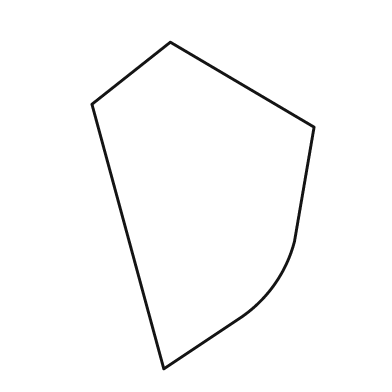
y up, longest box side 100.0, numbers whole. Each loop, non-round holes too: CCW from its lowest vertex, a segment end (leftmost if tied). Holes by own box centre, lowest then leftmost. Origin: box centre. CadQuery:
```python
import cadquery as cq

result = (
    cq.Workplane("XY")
    .moveTo(-12.0, -50.0)
    .lineTo(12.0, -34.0)
    .threePointArc((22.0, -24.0), (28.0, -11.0))
    .lineTo(34.0, 24.0)
    .lineTo(-10.0, 50.0)
    .lineTo(-34.0, 31.0)
    .close()
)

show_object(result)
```